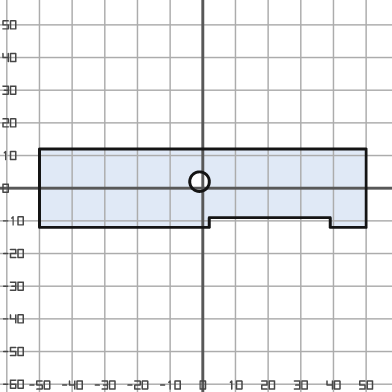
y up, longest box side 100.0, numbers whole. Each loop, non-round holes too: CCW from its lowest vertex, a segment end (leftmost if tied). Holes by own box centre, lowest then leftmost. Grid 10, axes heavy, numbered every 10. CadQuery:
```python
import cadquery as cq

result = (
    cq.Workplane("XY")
    .moveTo(-50.0, -12.0)
    .lineTo(2.0, -12.0)
    .lineTo(2.0, -9.0)
    .lineTo(39.0, -9.0)
    .lineTo(39.0, -12.0)
    .lineTo(50.0, -12.0)
    .lineTo(50.0, 12.0)
    .lineTo(-50.0, 12.0)
    .close()
    .moveTo(-1.0, 2.0)
    .circle(3.0)
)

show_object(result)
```